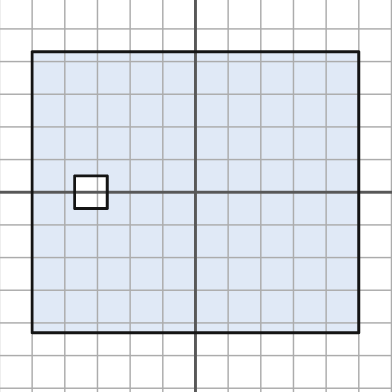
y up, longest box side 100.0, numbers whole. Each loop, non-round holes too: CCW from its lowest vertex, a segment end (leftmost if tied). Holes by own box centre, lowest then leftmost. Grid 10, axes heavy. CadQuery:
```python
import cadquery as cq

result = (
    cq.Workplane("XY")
    .moveTo(-50.0, -43.0)
    .lineTo(50.0, -43.0)
    .lineTo(50.0, 43.0)
    .lineTo(-50.0, 43.0)
    .close()
    .moveTo(-37.0, -5.0)
    .lineTo(-27.0, -5.0)
    .lineTo(-27.0, 5.0)
    .lineTo(-37.0, 5.0)
    .close()
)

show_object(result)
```